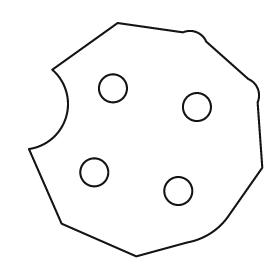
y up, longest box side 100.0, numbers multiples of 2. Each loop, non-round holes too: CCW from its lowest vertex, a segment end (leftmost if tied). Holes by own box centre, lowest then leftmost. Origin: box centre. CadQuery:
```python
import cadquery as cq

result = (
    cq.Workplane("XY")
    .moveTo(-4.0, -50.0)
    .lineTo(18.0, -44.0)
    .threePointArc((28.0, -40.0), (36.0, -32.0))
    .lineTo(50.0, -12.0)
    .lineTo(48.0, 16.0)
    .threePointArc((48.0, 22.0), (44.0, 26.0))
    .lineTo(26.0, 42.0)
    .threePointArc((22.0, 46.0), (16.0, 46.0))
    .lineTo(-12.0, 50.0)
    .lineTo(-40.0, 30.0)
    .threePointArc((-34.0, 10.0), (-50.0, -4.0))
    .lineTo(-36.0, -36.0)
    .close()
    .moveTo(14.0, -22.0)
    .circle(6.0)
    .moveTo(-22.0, -14.0)
    .circle(6.0)
    .moveTo(22.0, 14.0)
    .circle(6.0)
    .moveTo(-14.0, 22.0)
    .circle(6.0)
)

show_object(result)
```